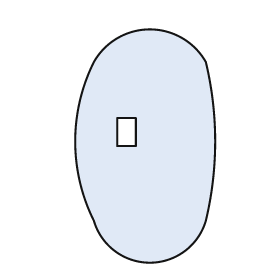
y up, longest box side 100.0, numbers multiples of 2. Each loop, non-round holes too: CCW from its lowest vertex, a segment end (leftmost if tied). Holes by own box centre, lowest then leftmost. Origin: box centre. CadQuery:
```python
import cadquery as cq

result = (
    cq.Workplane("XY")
    .moveTo(-22.0, -32.0)
    .threePointArc((2.0, -50.0), (26.0, -32.0))
    .threePointArc((30.0, 2.0), (26.0, 36.0))
    .threePointArc((2.0, 50.0), (-22.0, 36.0))
    .threePointArc((-30.0, 2.0), (-22.0, -32.0))
    .close()
    .moveTo(-12.0, 0.0)
    .lineTo(-4.0, 0.0)
    .lineTo(-4.0, 12.0)
    .lineTo(-12.0, 12.0)
    .close()
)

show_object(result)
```